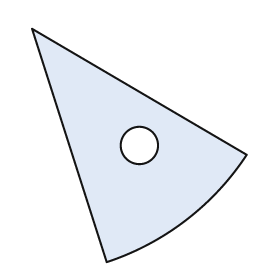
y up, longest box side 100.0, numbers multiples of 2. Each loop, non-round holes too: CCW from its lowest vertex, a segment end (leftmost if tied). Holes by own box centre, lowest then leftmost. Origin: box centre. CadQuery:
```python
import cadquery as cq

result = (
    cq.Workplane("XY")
    .moveTo(-14.0, -50.0)
    .threePointArc((20.0, -32.0), (46.0, -4.0))
    .lineTo(-46.0, 50.0)
    .close()
    .moveTo(0.0, 0.0)
    .circle(8.0)
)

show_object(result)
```